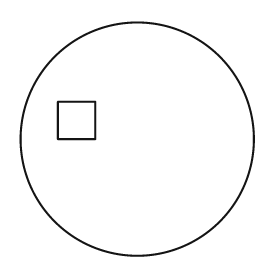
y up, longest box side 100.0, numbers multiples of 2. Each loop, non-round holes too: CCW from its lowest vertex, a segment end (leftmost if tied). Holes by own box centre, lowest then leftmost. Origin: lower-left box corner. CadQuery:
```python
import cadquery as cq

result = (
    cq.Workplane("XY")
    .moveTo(50.0, 50.0)
    .circle(50.0)
    .moveTo(16.0, 50.0)
    .lineTo(32.0, 50.0)
    .lineTo(32.0, 66.0)
    .lineTo(16.0, 66.0)
    .close()
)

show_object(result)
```